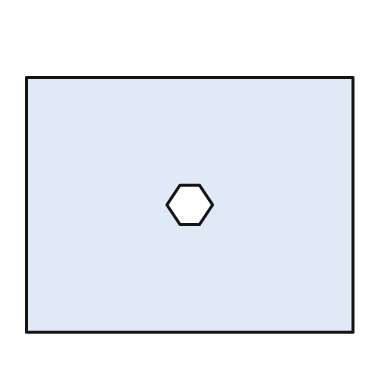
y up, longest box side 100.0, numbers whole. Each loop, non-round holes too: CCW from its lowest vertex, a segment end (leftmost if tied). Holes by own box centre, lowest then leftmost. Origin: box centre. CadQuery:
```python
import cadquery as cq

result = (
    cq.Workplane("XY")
    .moveTo(-50.0, -39.0)
    .lineTo(50.0, -39.0)
    .lineTo(50.0, 39.0)
    .lineTo(-50.0, 39.0)
    .close()
    .moveTo(-3.0, -6.0)
    .lineTo(3.0, -6.0)
    .lineTo(7.0, 0.0)
    .lineTo(3.0, 6.0)
    .lineTo(-3.0, 6.0)
    .lineTo(-7.0, 0.0)
    .close()
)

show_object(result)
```